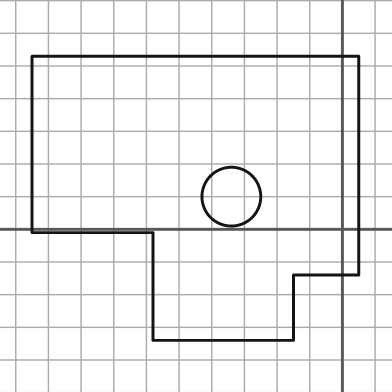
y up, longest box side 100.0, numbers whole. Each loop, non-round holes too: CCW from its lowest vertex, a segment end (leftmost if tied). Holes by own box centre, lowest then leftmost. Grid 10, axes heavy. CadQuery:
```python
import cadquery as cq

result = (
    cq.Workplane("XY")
    .moveTo(-58.0, -34.0)
    .lineTo(-15.0, -34.0)
    .lineTo(-15.0, -14.0)
    .lineTo(5.0, -14.0)
    .lineTo(5.0, 53.0)
    .lineTo(-95.0, 53.0)
    .lineTo(-95.0, -1.0)
    .lineTo(-58.0, -1.0)
    .close()
    .moveTo(-34.0, 10.0)
    .circle(9.0)
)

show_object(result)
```